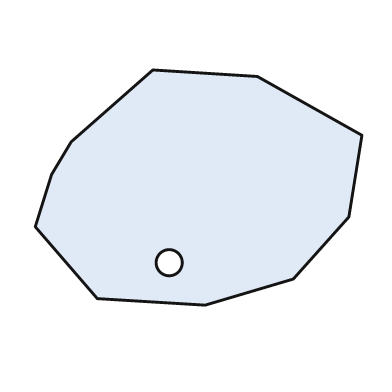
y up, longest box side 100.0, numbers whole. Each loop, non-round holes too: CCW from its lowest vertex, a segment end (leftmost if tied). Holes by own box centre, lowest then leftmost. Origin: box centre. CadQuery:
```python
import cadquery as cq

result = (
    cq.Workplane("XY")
    .moveTo(2.0, -36.0)
    .lineTo(29.0, -28.0)
    .lineTo(46.0, -9.0)
    .lineTo(50.0, 16.0)
    .lineTo(18.0, 34.0)
    .lineTo(-14.0, 36.0)
    .lineTo(-39.0, 14.0)
    .lineTo(-45.0, 4.0)
    .lineTo(-50.0, -12.0)
    .lineTo(-31.0, -34.0)
    .close()
    .moveTo(-9.0, -23.0)
    .circle(4.0)
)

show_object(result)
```